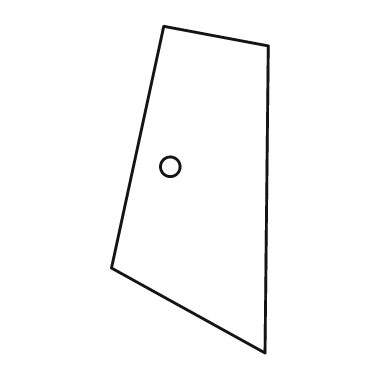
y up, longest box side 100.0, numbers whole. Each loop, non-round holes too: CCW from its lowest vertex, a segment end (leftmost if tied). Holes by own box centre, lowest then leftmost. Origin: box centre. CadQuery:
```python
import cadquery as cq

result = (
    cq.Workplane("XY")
    .moveTo(23.0, -50.0)
    .lineTo(24.0, 44.0)
    .lineTo(-8.0, 50.0)
    .lineTo(-24.0, -24.0)
    .close()
    .moveTo(-6.0, 7.0)
    .circle(3.0)
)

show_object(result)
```